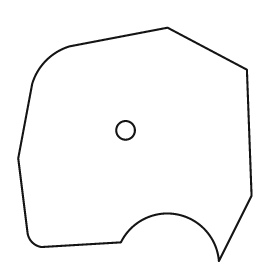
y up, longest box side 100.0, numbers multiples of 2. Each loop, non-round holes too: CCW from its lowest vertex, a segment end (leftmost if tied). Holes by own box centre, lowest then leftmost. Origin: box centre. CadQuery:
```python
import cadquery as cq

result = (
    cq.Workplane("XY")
    .moveTo(36.0, -50.0)
    .lineTo(50.0, -22.0)
    .lineTo(48.0, 32.0)
    .lineTo(14.0, 50.0)
    .lineTo(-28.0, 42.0)
    .threePointArc((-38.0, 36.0), (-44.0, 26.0))
    .lineTo(-50.0, -6.0)
    .lineTo(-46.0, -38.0)
    .threePointArc((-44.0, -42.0), (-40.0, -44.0))
    .lineTo(-6.0, -42.0)
    .threePointArc((18.0, -30.0), (36.0, -50.0))
    .close()
    .moveTo(-4.0, 6.0)
    .circle(4.0)
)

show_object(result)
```